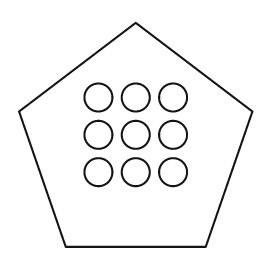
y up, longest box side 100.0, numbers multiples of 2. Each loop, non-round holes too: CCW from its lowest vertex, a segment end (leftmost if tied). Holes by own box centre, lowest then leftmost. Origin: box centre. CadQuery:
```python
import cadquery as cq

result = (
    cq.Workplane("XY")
    .moveTo(-30.0, -48.0)
    .lineTo(30.0, -48.0)
    .lineTo(50.0, 10.0)
    .lineTo(0.0, 48.0)
    .lineTo(-50.0, 10.0)
    .close()
    .moveTo(-16.0, -16.0)
    .circle(6.0)
    .moveTo(0.0, -16.0)
    .circle(6.0)
    .moveTo(16.0, -16.0)
    .circle(6.0)
    .moveTo(-16.0, 0.0)
    .circle(6.0)
    .moveTo(0.0, 0.0)
    .circle(6.0)
    .moveTo(16.0, 0.0)
    .circle(6.0)
    .moveTo(-16.0, 16.0)
    .circle(6.0)
    .moveTo(0.0, 16.0)
    .circle(6.0)
    .moveTo(16.0, 16.0)
    .circle(6.0)
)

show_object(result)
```